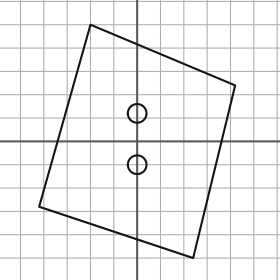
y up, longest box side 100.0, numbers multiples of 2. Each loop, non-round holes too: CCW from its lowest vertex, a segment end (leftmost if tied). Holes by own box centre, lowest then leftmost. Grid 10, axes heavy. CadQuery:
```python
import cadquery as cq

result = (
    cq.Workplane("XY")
    .moveTo(24.0, -50.0)
    .lineTo(42.0, 24.0)
    .lineTo(-20.0, 50.0)
    .lineTo(-42.0, -28.0)
    .close()
    .moveTo(0.0, -10.0)
    .circle(4.0)
    .moveTo(0.0, 12.0)
    .circle(4.0)
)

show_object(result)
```